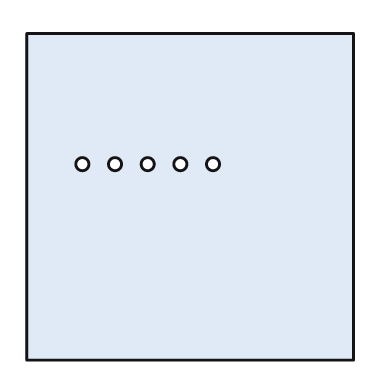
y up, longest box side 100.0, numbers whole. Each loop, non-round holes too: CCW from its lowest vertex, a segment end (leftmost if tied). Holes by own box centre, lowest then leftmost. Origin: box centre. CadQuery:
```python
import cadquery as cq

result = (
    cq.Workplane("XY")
    .moveTo(-50.0, -50.0)
    .lineTo(50.0, -50.0)
    .lineTo(50.0, 50.0)
    .lineTo(-50.0, 50.0)
    .close()
    .moveTo(-33.0, 10.0)
    .circle(2.0)
    .moveTo(-23.0, 10.0)
    .circle(2.0)
    .moveTo(-13.0, 10.0)
    .circle(2.0)
    .moveTo(-3.0, 10.0)
    .circle(2.0)
    .moveTo(7.0, 10.0)
    .circle(2.0)
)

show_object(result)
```